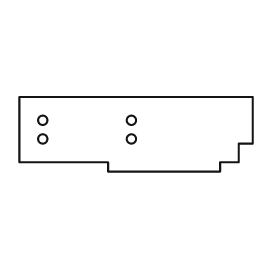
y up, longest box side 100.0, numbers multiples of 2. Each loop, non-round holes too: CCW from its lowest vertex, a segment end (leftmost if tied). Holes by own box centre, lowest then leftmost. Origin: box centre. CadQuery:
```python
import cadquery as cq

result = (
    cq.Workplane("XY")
    .moveTo(-12.0, -16.0)
    .lineTo(36.0, -16.0)
    .lineTo(36.0, -12.0)
    .lineTo(44.0, -12.0)
    .lineTo(44.0, -4.0)
    .lineTo(50.0, -4.0)
    .lineTo(50.0, 16.0)
    .lineTo(-50.0, 16.0)
    .lineTo(-50.0, -12.0)
    .lineTo(-12.0, -12.0)
    .close()
    .moveTo(-40.0, -2.0)
    .circle(2.0)
    .moveTo(-2.0, -2.0)
    .circle(2.0)
    .moveTo(-40.0, 6.0)
    .circle(2.0)
    .moveTo(-2.0, 6.0)
    .circle(2.0)
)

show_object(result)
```